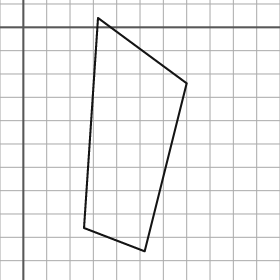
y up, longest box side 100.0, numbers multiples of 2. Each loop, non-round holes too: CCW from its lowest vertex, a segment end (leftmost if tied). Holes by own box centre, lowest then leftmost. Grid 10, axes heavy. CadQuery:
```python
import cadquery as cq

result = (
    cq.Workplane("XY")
    .moveTo(52.0, -96.0)
    .lineTo(70.0, -24.0)
    .lineTo(32.0, 4.0)
    .lineTo(26.0, -86.0)
    .close()
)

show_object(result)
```